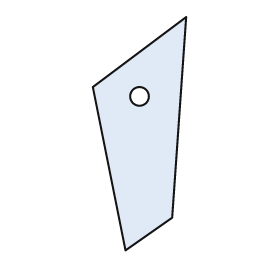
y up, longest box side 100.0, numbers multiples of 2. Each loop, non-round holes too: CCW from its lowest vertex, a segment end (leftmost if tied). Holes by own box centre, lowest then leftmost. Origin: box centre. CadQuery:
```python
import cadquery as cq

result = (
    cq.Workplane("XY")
    .moveTo(-6.0, -50.0)
    .lineTo(14.0, -36.0)
    .lineTo(20.0, 50.0)
    .lineTo(-20.0, 20.0)
    .close()
    .moveTo(0.0, 16.0)
    .circle(4.0)
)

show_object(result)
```